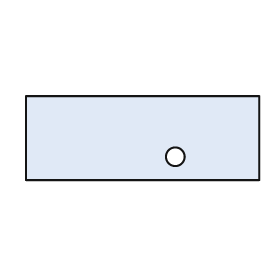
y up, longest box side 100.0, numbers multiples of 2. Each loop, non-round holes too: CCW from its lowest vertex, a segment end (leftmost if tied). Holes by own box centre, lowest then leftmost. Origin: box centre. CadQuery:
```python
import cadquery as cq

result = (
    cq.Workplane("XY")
    .moveTo(-50.0, -18.0)
    .lineTo(50.0, -18.0)
    .lineTo(50.0, 18.0)
    .lineTo(-50.0, 18.0)
    .close()
    .moveTo(14.0, -8.0)
    .circle(4.0)
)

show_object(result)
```